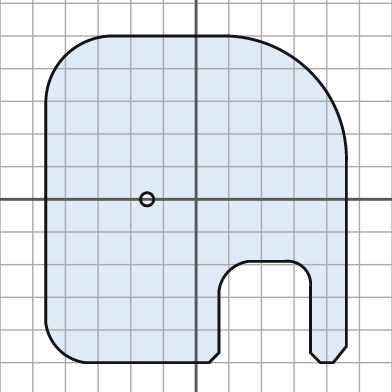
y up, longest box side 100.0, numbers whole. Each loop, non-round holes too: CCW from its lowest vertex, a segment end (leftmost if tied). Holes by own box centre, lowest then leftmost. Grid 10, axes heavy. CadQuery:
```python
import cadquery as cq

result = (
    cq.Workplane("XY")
    .moveTo(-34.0, -50.0)
    .lineTo(4.0, -50.0)
    .lineTo(7.0, -47.0)
    .lineTo(7.0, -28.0)
    .threePointArc((10.0, -22.0), (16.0, -19.0))
    .lineTo(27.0, -19.0)
    .threePointArc((33.0, -21.0), (35.0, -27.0))
    .lineTo(35.0, -47.0)
    .lineTo(38.0, -50.0)
    .lineTo(42.0, -50.0)
    .lineTo(46.0, -45.0)
    .lineTo(46.0, 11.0)
    .threePointArc((35.0, 39.0), (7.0, 50.0))
    .lineTo(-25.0, 50.0)
    .threePointArc((-40.0, 44.0), (-46.0, 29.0))
    .lineTo(-46.0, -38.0)
    .threePointArc((-42.0, -46.0), (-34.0, -50.0))
    .close()
    .moveTo(-15.0, 0.0)
    .circle(2.0)
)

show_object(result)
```